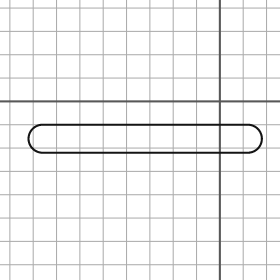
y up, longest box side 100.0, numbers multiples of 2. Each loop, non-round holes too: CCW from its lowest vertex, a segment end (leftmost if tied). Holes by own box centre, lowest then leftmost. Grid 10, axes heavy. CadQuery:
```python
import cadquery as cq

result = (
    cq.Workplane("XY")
    .moveTo(-76.0, -22.0)
    .lineTo(12.0, -22.0)
    .threePointArc((18.0, -16.0), (12.0, -10.0))
    .lineTo(-76.0, -10.0)
    .threePointArc((-82.0, -16.0), (-76.0, -22.0))
    .close()
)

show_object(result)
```